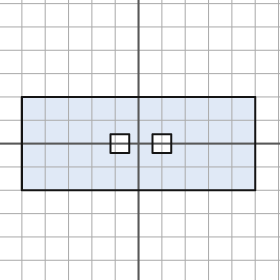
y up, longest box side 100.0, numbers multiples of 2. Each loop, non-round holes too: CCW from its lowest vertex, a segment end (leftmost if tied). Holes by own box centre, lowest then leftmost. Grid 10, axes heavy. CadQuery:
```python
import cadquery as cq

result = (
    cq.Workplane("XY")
    .moveTo(-50.0, -20.0)
    .lineTo(50.0, -20.0)
    .lineTo(50.0, 20.0)
    .lineTo(-50.0, 20.0)
    .close()
    .moveTo(-12.0, -4.0)
    .lineTo(-4.0, -4.0)
    .lineTo(-4.0, 4.0)
    .lineTo(-12.0, 4.0)
    .close()
    .moveTo(6.0, -4.0)
    .lineTo(14.0, -4.0)
    .lineTo(14.0, 4.0)
    .lineTo(6.0, 4.0)
    .close()
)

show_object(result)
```